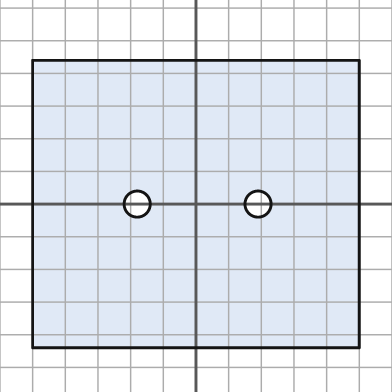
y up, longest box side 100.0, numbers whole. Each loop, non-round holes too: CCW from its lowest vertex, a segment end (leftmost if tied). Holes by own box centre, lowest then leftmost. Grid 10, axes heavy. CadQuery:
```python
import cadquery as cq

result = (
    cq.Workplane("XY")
    .moveTo(-50.0, -44.0)
    .lineTo(50.0, -44.0)
    .lineTo(50.0, 44.0)
    .lineTo(-50.0, 44.0)
    .close()
    .moveTo(-18.0, 0.0)
    .circle(4.0)
    .moveTo(19.0, 0.0)
    .circle(4.0)
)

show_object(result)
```